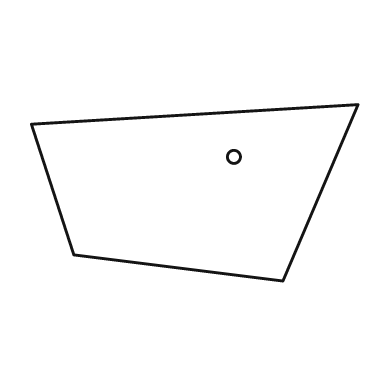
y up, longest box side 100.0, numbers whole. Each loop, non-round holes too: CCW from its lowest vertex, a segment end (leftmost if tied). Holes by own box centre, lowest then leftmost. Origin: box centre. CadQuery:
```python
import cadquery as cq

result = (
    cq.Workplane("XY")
    .moveTo(27.0, -27.0)
    .lineTo(50.0, 27.0)
    .lineTo(-50.0, 21.0)
    .lineTo(-37.0, -19.0)
    .close()
    .moveTo(12.0, 11.0)
    .circle(2.0)
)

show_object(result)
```